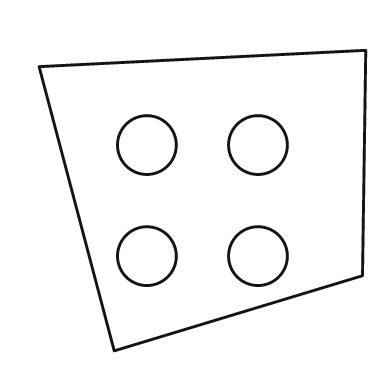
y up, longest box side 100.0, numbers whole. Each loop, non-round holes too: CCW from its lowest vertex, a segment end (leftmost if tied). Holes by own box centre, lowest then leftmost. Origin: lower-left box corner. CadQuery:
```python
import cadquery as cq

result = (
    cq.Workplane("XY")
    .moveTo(23.0, 0.0)
    .lineTo(99.0, 23.0)
    .lineTo(100.0, 92.0)
    .lineTo(0.0, 87.0)
    .close()
    .moveTo(33.0, 29.0)
    .circle(9.0)
    .moveTo(67.0, 29.0)
    .circle(9.0)
    .moveTo(33.0, 63.0)
    .circle(9.0)
    .moveTo(67.0, 63.0)
    .circle(9.0)
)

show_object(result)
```